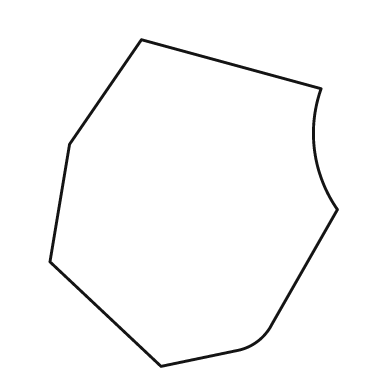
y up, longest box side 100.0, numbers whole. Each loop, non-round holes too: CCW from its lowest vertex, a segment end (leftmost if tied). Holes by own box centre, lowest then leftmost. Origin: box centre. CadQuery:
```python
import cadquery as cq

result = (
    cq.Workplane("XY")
    .moveTo(-10.0, -50.0)
    .lineTo(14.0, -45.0)
    .threePointArc((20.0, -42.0), (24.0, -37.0))
    .lineTo(44.0, -2.0)
    .threePointArc((37.0, 16.0), (39.0, 35.0))
    .lineTo(-16.0, 50.0)
    .lineTo(-38.0, 18.0)
    .lineTo(-44.0, -18.0)
    .close()
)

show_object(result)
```